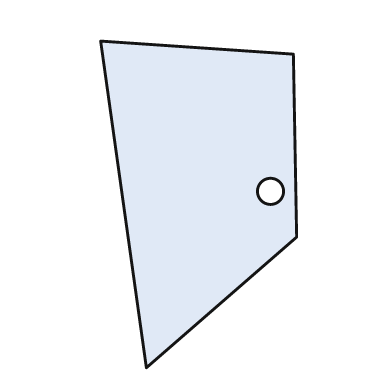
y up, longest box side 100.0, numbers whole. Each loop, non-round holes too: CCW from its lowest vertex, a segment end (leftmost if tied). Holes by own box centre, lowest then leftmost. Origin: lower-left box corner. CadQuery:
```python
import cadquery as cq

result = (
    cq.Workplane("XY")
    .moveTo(14.0, 0.0)
    .lineTo(60.0, 40.0)
    .lineTo(59.0, 96.0)
    .lineTo(0.0, 100.0)
    .close()
    .moveTo(52.0, 54.0)
    .circle(4.0)
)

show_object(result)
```